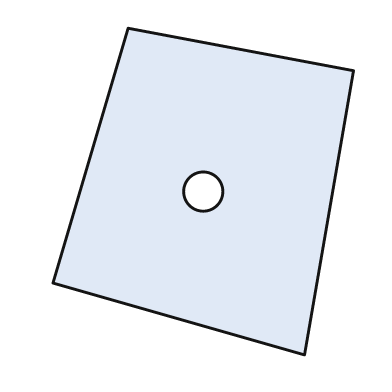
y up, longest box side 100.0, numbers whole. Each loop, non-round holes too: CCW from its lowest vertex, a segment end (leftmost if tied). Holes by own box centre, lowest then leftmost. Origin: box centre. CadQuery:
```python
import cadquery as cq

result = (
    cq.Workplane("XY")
    .moveTo(31.0, -50.0)
    .lineTo(46.0, 37.0)
    .lineTo(-23.0, 50.0)
    .lineTo(-46.0, -28.0)
    .close()
    .moveTo(0.0, 0.0)
    .circle(6.0)
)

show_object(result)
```